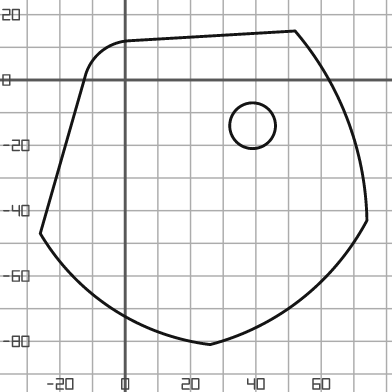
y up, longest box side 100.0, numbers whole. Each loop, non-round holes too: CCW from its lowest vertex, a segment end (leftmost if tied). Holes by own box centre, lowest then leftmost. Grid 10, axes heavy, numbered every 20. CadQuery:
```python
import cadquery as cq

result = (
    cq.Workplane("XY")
    .moveTo(26.0, -81.0)
    .threePointArc((54.0, -67.0), (74.0, -43.0))
    .threePointArc((68.0, -12.0), (52.0, 15.0))
    .lineTo(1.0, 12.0)
    .threePointArc((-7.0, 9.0), (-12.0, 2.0))
    .lineTo(-26.0, -47.0)
    .threePointArc((-4.0, -70.0), (26.0, -81.0))
    .close()
    .moveTo(39.0, -14.0)
    .circle(7.0)
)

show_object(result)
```